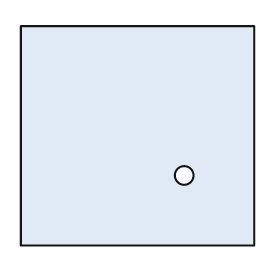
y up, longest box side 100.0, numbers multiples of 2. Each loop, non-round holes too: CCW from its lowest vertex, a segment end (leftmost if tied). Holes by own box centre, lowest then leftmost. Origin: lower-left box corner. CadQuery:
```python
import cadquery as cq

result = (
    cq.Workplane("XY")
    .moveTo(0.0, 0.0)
    .lineTo(100.0, 0.0)
    .lineTo(100.0, 94.0)
    .lineTo(0.0, 94.0)
    .close()
    .moveTo(70.0, 30.0)
    .circle(4.0)
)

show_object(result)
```